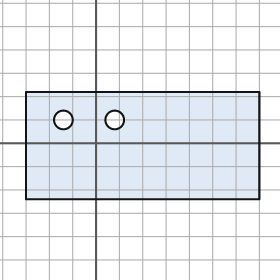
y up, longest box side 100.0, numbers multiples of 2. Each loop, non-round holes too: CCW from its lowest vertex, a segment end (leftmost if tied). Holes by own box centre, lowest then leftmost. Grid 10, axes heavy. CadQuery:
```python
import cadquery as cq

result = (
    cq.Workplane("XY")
    .moveTo(-30.0, -24.0)
    .lineTo(70.0, -24.0)
    .lineTo(70.0, 22.0)
    .lineTo(-30.0, 22.0)
    .close()
    .moveTo(-14.0, 10.0)
    .circle(4.0)
    .moveTo(8.0, 10.0)
    .circle(4.0)
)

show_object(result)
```